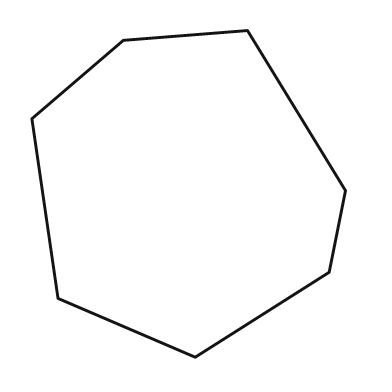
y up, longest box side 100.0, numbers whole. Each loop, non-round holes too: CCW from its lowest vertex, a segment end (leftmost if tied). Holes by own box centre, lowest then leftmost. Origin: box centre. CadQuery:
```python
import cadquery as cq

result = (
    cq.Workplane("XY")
    .moveTo(2.0, -50.0)
    .lineTo(43.0, -24.0)
    .lineTo(48.0, 1.0)
    .lineTo(18.0, 50.0)
    .lineTo(-20.0, 47.0)
    .lineTo(-48.0, 23.0)
    .lineTo(-40.0, -32.0)
    .close()
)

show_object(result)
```